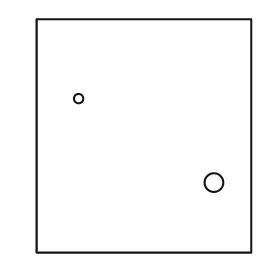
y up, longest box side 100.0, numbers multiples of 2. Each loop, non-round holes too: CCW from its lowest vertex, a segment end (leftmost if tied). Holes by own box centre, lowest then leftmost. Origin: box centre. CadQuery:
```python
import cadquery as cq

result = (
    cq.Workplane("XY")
    .moveTo(-46.0, -50.0)
    .lineTo(46.0, -50.0)
    .lineTo(46.0, 50.0)
    .lineTo(-46.0, 50.0)
    .close()
    .moveTo(30.0, -20.0)
    .circle(4.0)
    .moveTo(-28.0, 16.0)
    .circle(2.0)
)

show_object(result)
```